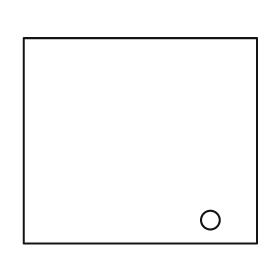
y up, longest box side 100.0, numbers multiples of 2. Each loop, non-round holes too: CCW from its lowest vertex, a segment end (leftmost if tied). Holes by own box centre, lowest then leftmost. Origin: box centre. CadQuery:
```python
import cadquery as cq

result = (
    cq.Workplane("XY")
    .moveTo(-50.0, -44.0)
    .lineTo(50.0, -44.0)
    .lineTo(50.0, 44.0)
    .lineTo(-50.0, 44.0)
    .close()
    .moveTo(30.0, -34.0)
    .circle(4.0)
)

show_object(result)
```